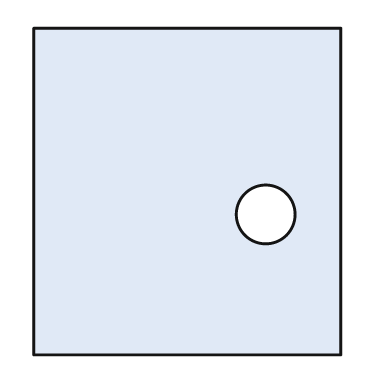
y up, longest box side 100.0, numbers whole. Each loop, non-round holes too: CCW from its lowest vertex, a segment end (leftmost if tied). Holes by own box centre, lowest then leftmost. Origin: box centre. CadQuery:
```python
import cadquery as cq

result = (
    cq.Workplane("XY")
    .moveTo(-47.0, -50.0)
    .lineTo(47.0, -50.0)
    .lineTo(47.0, 50.0)
    .lineTo(-47.0, 50.0)
    .close()
    .moveTo(24.0, -7.0)
    .circle(9.0)
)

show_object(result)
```